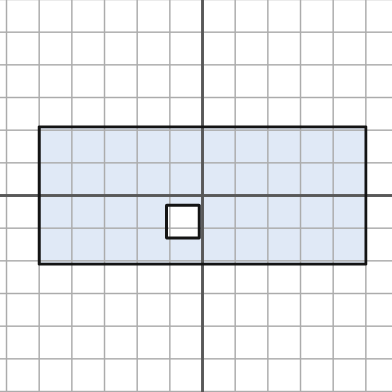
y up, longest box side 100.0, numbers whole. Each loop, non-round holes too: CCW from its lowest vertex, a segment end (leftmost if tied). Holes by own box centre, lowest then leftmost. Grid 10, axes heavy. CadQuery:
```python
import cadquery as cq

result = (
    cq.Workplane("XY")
    .moveTo(-50.0, -21.0)
    .lineTo(50.0, -21.0)
    .lineTo(50.0, 21.0)
    .lineTo(-50.0, 21.0)
    .close()
    .moveTo(-11.0, -13.0)
    .lineTo(-1.0, -13.0)
    .lineTo(-1.0, -3.0)
    .lineTo(-11.0, -3.0)
    .close()
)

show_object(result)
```